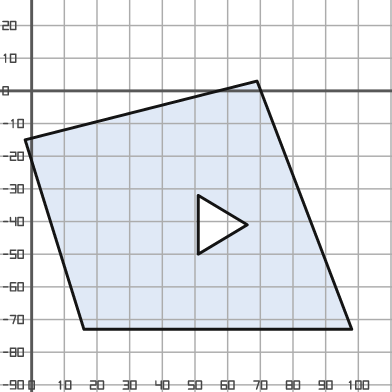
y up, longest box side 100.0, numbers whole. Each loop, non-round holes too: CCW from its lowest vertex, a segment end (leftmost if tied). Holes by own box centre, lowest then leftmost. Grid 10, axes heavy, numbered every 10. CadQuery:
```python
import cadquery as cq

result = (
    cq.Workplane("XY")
    .moveTo(16.0, -73.0)
    .lineTo(98.0, -73.0)
    .lineTo(69.0, 3.0)
    .lineTo(-2.0, -15.0)
    .close()
    .moveTo(51.0, -50.0)
    .lineTo(66.0, -41.0)
    .lineTo(51.0, -32.0)
    .close()
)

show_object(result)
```